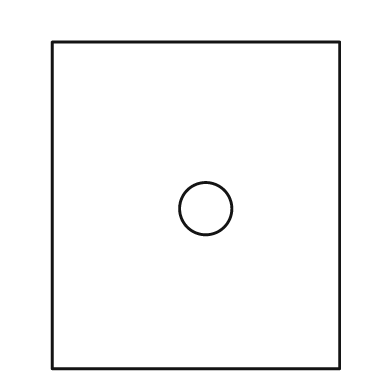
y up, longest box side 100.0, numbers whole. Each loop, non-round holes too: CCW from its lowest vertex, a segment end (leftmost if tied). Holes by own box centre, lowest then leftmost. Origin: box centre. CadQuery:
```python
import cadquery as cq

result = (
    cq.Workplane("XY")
    .moveTo(-44.0, -50.0)
    .lineTo(44.0, -50.0)
    .lineTo(44.0, 50.0)
    .lineTo(-44.0, 50.0)
    .close()
    .moveTo(3.0, -1.0)
    .circle(8.0)
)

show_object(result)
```